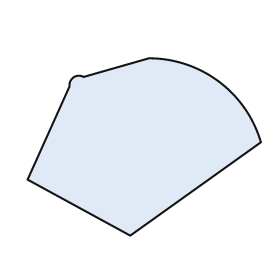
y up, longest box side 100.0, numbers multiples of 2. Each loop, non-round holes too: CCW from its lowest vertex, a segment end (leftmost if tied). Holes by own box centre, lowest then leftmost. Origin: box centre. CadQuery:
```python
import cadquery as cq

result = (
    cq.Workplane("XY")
    .moveTo(-6.0, -38.0)
    .lineTo(50.0, 2.0)
    .threePointArc((32.0, 28.0), (2.0, 38.0))
    .lineTo(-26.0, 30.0)
    .threePointArc((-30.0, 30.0), (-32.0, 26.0))
    .lineTo(-50.0, -14.0)
    .close()
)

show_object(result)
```